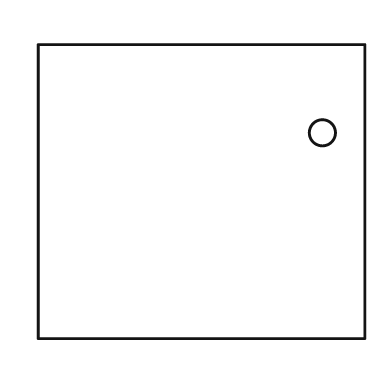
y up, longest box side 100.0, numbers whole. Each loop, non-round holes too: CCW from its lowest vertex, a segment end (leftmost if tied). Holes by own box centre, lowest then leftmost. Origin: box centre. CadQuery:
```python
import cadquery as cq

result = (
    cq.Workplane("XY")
    .moveTo(-50.0, -45.0)
    .lineTo(50.0, -45.0)
    .lineTo(50.0, 45.0)
    .lineTo(-50.0, 45.0)
    .close()
    .moveTo(37.0, 18.0)
    .circle(4.0)
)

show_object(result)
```